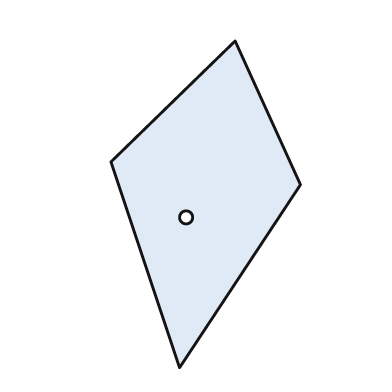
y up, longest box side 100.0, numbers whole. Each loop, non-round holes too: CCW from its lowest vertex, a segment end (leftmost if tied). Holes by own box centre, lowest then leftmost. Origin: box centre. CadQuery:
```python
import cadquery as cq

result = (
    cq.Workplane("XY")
    .moveTo(-8.0, -50.0)
    .lineTo(29.0, 6.0)
    .lineTo(9.0, 50.0)
    .lineTo(-29.0, 13.0)
    .close()
    .moveTo(-6.0, -4.0)
    .circle(2.0)
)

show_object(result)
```